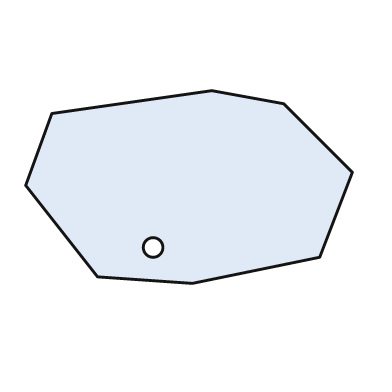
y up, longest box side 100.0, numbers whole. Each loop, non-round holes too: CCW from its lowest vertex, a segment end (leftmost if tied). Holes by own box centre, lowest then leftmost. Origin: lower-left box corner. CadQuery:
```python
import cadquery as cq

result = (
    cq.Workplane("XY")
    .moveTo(51.0, 0.0)
    .lineTo(90.0, 8.0)
    .lineTo(100.0, 34.0)
    .lineTo(79.0, 55.0)
    .lineTo(57.0, 59.0)
    .lineTo(8.0, 52.0)
    .lineTo(0.0, 30.0)
    .lineTo(22.0, 2.0)
    .close()
    .moveTo(39.0, 11.0)
    .circle(3.0)
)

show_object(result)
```